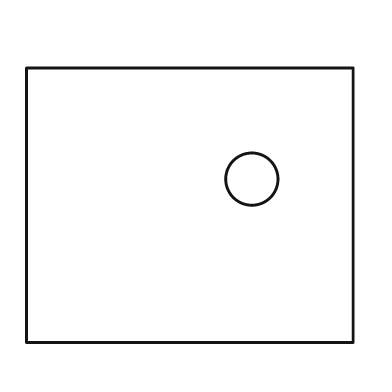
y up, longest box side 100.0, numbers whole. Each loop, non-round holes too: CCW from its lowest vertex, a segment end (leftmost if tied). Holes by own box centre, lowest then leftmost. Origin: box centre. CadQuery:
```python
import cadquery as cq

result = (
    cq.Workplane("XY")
    .moveTo(-50.0, -42.0)
    .lineTo(50.0, -42.0)
    .lineTo(50.0, 42.0)
    .lineTo(-50.0, 42.0)
    .close()
    .moveTo(19.0, 8.0)
    .circle(8.0)
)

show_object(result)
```